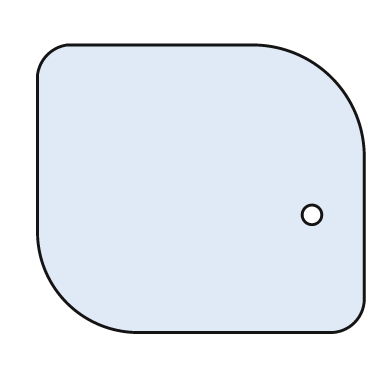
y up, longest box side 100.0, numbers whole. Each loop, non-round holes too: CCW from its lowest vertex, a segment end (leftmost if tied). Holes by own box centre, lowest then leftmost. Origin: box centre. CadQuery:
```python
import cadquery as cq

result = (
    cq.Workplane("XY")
    .moveTo(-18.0, -44.0)
    .lineTo(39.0, -44.0)
    .threePointArc((47.0, -41.0), (50.0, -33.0))
    .lineTo(50.0, 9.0)
    .threePointArc((40.0, 34.0), (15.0, 44.0))
    .lineTo(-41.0, 44.0)
    .threePointArc((-47.0, 41.0), (-50.0, 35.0))
    .lineTo(-50.0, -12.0)
    .threePointArc((-41.0, -35.0), (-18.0, -44.0))
    .close()
    .moveTo(34.0, -8.0)
    .circle(3.0)
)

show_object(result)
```